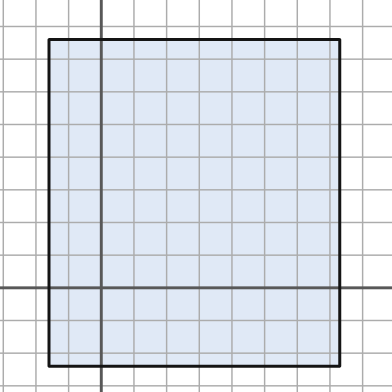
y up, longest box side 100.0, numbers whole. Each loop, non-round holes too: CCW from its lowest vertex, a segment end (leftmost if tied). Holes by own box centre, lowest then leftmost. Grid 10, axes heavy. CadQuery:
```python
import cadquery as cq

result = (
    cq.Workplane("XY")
    .moveTo(-16.0, -24.0)
    .lineTo(73.0, -24.0)
    .lineTo(73.0, 76.0)
    .lineTo(-16.0, 76.0)
    .close()
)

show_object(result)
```